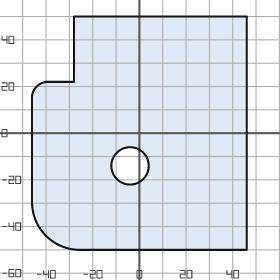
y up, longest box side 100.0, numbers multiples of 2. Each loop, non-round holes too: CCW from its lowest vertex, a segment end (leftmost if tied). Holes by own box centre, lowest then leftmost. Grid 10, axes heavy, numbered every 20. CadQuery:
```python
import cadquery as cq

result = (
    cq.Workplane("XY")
    .moveTo(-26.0, -50.0)
    .lineTo(46.0, -50.0)
    .lineTo(46.0, 50.0)
    .lineTo(-28.0, 50.0)
    .lineTo(-28.0, 22.0)
    .lineTo(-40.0, 22.0)
    .threePointArc((-44.0, 20.0), (-46.0, 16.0))
    .lineTo(-46.0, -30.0)
    .threePointArc((-40.0, -44.0), (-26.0, -50.0))
    .close()
    .moveTo(-4.0, -14.0)
    .circle(8.0)
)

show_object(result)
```